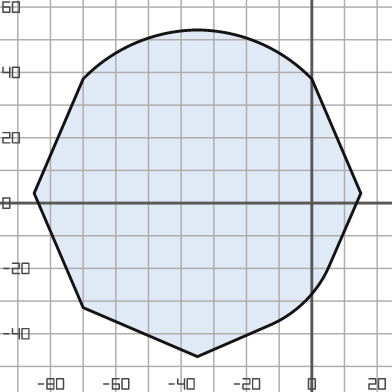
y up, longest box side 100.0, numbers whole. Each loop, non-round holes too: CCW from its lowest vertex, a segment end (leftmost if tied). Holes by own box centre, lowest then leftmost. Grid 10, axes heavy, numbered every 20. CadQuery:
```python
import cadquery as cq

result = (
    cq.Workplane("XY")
    .moveTo(-35.0, -47.0)
    .lineTo(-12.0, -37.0)
    .threePointArc((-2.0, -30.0), (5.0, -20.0))
    .lineTo(15.0, 3.0)
    .lineTo(0.0, 38.0)
    .threePointArc((-16.0, 49.0), (-35.0, 53.0))
    .threePointArc((-54.0, 49.0), (-70.0, 38.0))
    .lineTo(-85.0, 3.0)
    .lineTo(-70.0, -32.0)
    .close()
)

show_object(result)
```